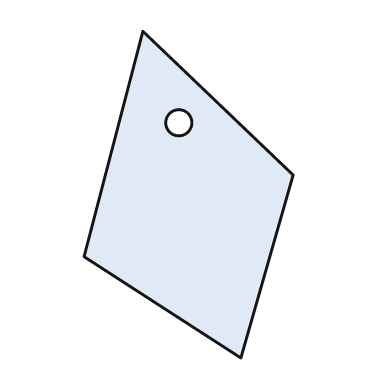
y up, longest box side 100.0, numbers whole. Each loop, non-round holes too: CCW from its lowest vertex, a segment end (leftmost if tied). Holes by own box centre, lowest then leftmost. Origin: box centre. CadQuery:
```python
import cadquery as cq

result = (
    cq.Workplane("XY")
    .moveTo(16.0, -50.0)
    .lineTo(32.0, 6.0)
    .lineTo(-14.0, 50.0)
    .lineTo(-32.0, -19.0)
    .close()
    .moveTo(-3.0, 22.0)
    .circle(4.0)
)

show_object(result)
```